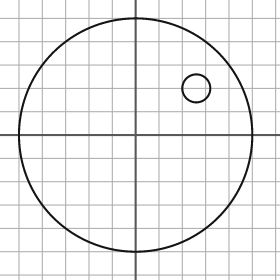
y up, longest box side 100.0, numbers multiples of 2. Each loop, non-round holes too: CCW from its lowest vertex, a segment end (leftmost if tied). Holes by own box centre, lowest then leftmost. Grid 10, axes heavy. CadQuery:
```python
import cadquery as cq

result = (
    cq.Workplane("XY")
    .moveTo(0.0, 0.0)
    .circle(50.0)
    .moveTo(26.0, 20.0)
    .circle(6.0)
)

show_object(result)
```